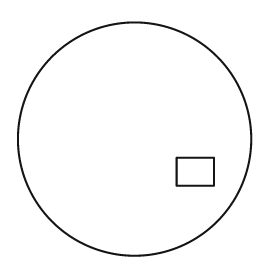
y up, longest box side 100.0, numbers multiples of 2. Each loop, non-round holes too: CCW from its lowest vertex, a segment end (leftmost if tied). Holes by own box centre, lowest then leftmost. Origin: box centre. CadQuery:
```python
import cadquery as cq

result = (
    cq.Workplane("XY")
    .moveTo(0.0, 0.0)
    .circle(50.0)
    .moveTo(18.0, -20.0)
    .lineTo(34.0, -20.0)
    .lineTo(34.0, -8.0)
    .lineTo(18.0, -8.0)
    .close()
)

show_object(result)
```